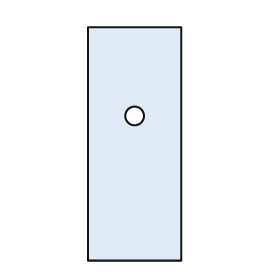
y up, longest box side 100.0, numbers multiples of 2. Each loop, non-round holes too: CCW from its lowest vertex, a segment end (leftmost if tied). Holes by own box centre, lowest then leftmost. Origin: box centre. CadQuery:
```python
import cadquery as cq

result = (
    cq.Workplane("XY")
    .moveTo(-20.0, -50.0)
    .lineTo(20.0, -50.0)
    .lineTo(20.0, 50.0)
    .lineTo(-20.0, 50.0)
    .close()
    .moveTo(0.0, 12.0)
    .circle(4.0)
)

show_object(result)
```